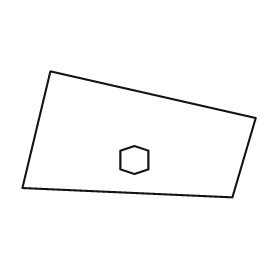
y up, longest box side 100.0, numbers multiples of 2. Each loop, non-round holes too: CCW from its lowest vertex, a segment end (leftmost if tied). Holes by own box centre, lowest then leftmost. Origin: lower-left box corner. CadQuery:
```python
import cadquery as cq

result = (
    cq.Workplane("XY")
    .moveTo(90.0, 0.0)
    .lineTo(100.0, 34.0)
    .lineTo(12.0, 54.0)
    .lineTo(0.0, 4.0)
    .close()
    .moveTo(48.0, 10.0)
    .lineTo(54.0, 12.0)
    .lineTo(54.0, 20.0)
    .lineTo(48.0, 22.0)
    .lineTo(42.0, 20.0)
    .lineTo(42.0, 12.0)
    .close()
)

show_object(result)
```